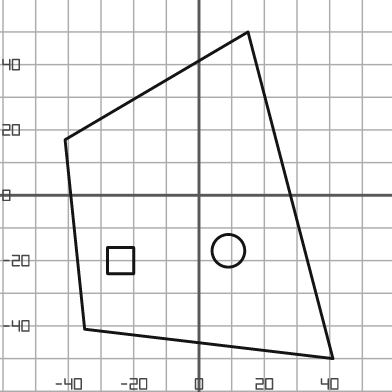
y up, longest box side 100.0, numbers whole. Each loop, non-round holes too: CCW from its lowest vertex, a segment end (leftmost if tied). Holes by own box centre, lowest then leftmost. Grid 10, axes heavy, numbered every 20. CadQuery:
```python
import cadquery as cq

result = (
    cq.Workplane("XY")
    .moveTo(41.0, -50.0)
    .lineTo(15.0, 50.0)
    .lineTo(-41.0, 17.0)
    .lineTo(-35.0, -41.0)
    .close()
    .moveTo(-28.0, -24.0)
    .lineTo(-20.0, -24.0)
    .lineTo(-20.0, -16.0)
    .lineTo(-28.0, -16.0)
    .close()
    .moveTo(9.0, -17.0)
    .circle(5.0)
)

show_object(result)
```